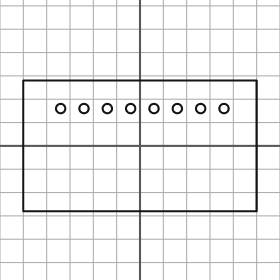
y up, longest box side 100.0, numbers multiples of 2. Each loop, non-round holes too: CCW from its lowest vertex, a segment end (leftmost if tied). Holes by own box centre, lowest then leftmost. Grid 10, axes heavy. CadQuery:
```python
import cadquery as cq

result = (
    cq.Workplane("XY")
    .moveTo(-50.0, -28.0)
    .lineTo(50.0, -28.0)
    .lineTo(50.0, 28.0)
    .lineTo(-50.0, 28.0)
    .close()
    .moveTo(-34.0, 16.0)
    .circle(2.0)
    .moveTo(-24.0, 16.0)
    .circle(2.0)
    .moveTo(-14.0, 16.0)
    .circle(2.0)
    .moveTo(-4.0, 16.0)
    .circle(2.0)
    .moveTo(6.0, 16.0)
    .circle(2.0)
    .moveTo(16.0, 16.0)
    .circle(2.0)
    .moveTo(26.0, 16.0)
    .circle(2.0)
    .moveTo(36.0, 16.0)
    .circle(2.0)
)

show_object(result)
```